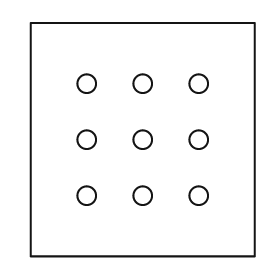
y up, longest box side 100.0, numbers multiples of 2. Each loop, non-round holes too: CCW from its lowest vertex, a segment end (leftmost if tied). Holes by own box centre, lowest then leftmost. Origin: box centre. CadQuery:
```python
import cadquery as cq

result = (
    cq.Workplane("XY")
    .moveTo(-48.0, -50.0)
    .lineTo(48.0, -50.0)
    .lineTo(48.0, 50.0)
    .lineTo(-48.0, 50.0)
    .close()
    .moveTo(-24.0, -24.0)
    .circle(4.0)
    .moveTo(0.0, -24.0)
    .circle(4.0)
    .moveTo(24.0, -24.0)
    .circle(4.0)
    .moveTo(-24.0, 0.0)
    .circle(4.0)
    .moveTo(0.0, 0.0)
    .circle(4.0)
    .moveTo(24.0, 0.0)
    .circle(4.0)
    .moveTo(-24.0, 24.0)
    .circle(4.0)
    .moveTo(0.0, 24.0)
    .circle(4.0)
    .moveTo(24.0, 24.0)
    .circle(4.0)
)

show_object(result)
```